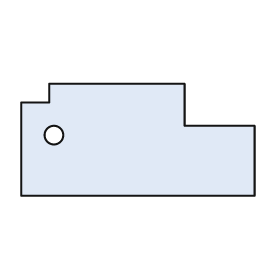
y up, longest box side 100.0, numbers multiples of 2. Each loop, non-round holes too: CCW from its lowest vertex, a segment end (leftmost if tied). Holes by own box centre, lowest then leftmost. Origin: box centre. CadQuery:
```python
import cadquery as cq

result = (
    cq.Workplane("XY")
    .moveTo(-50.0, -24.0)
    .lineTo(50.0, -24.0)
    .lineTo(50.0, 6.0)
    .lineTo(20.0, 6.0)
    .lineTo(20.0, 24.0)
    .lineTo(-38.0, 24.0)
    .lineTo(-38.0, 16.0)
    .lineTo(-50.0, 16.0)
    .close()
    .moveTo(-36.0, 2.0)
    .circle(4.0)
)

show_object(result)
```